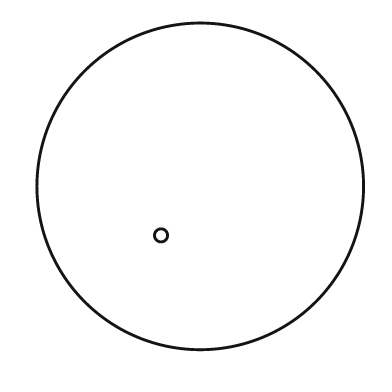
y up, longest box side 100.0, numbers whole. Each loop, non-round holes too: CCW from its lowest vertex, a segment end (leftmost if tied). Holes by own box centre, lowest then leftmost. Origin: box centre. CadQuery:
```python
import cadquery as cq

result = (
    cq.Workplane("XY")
    .moveTo(0.0, 0.0)
    .circle(50.0)
    .moveTo(-12.0, -15.0)
    .circle(2.0)
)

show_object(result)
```